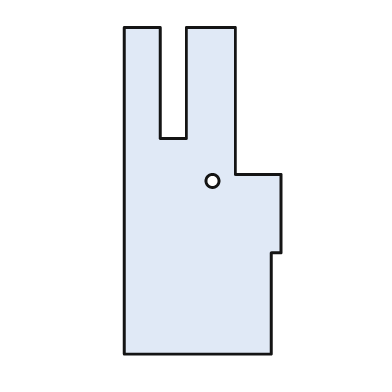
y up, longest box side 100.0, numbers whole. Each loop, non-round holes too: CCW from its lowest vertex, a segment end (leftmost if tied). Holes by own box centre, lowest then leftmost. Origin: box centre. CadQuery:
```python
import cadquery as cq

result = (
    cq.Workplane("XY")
    .moveTo(-24.0, -50.0)
    .lineTo(21.0, -50.0)
    .lineTo(21.0, -19.0)
    .lineTo(24.0, -19.0)
    .lineTo(24.0, 5.0)
    .lineTo(10.0, 5.0)
    .lineTo(10.0, 50.0)
    .lineTo(-5.0, 50.0)
    .lineTo(-5.0, 16.0)
    .lineTo(-13.0, 16.0)
    .lineTo(-13.0, 50.0)
    .lineTo(-24.0, 50.0)
    .close()
    .moveTo(3.0, 3.0)
    .circle(2.0)
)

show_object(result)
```